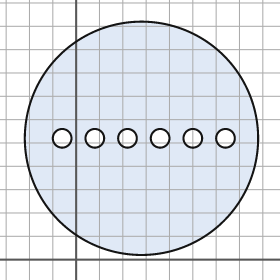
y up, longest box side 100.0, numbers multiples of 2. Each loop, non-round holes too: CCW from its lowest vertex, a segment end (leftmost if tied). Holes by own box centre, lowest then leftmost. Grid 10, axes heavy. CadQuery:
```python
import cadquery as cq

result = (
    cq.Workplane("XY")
    .moveTo(28.0, 52.0)
    .circle(50.0)
    .moveTo(-6.0, 52.0)
    .circle(4.0)
    .moveTo(8.0, 52.0)
    .circle(4.0)
    .moveTo(22.0, 52.0)
    .circle(4.0)
    .moveTo(36.0, 52.0)
    .circle(4.0)
    .moveTo(50.0, 52.0)
    .circle(4.0)
    .moveTo(64.0, 52.0)
    .circle(4.0)
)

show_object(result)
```